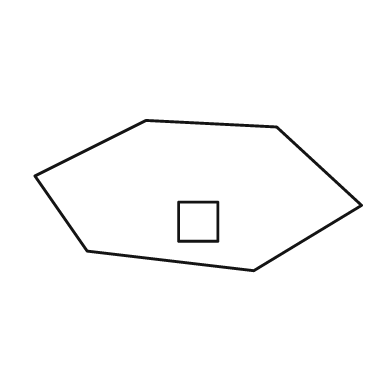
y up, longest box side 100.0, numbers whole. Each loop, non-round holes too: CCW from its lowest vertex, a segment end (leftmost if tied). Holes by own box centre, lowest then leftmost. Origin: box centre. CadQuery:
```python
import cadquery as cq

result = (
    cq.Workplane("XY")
    .moveTo(17.0, -23.0)
    .lineTo(50.0, -3.0)
    .lineTo(24.0, 21.0)
    .lineTo(-16.0, 23.0)
    .lineTo(-50.0, 6.0)
    .lineTo(-34.0, -17.0)
    .close()
    .moveTo(-6.0, -14.0)
    .lineTo(6.0, -14.0)
    .lineTo(6.0, -2.0)
    .lineTo(-6.0, -2.0)
    .close()
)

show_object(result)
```